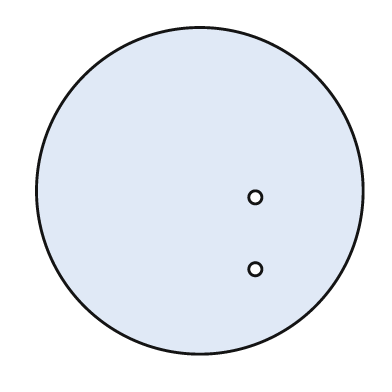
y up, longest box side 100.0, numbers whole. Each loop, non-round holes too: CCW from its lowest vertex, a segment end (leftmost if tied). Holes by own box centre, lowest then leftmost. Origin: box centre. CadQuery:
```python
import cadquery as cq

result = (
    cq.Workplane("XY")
    .moveTo(0.0, 0.0)
    .circle(50.0)
    .moveTo(17.0, -24.0)
    .circle(2.0)
    .moveTo(17.0, -2.0)
    .circle(2.0)
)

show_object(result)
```